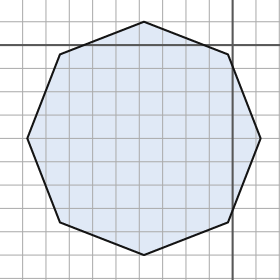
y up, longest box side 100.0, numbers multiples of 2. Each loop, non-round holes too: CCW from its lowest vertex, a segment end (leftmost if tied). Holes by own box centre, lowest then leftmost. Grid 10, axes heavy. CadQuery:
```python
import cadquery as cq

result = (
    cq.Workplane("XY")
    .moveTo(-38.0, -90.0)
    .lineTo(-2.0, -76.0)
    .lineTo(12.0, -40.0)
    .lineTo(-2.0, -4.0)
    .lineTo(-38.0, 10.0)
    .lineTo(-74.0, -4.0)
    .lineTo(-88.0, -40.0)
    .lineTo(-74.0, -76.0)
    .close()
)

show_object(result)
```